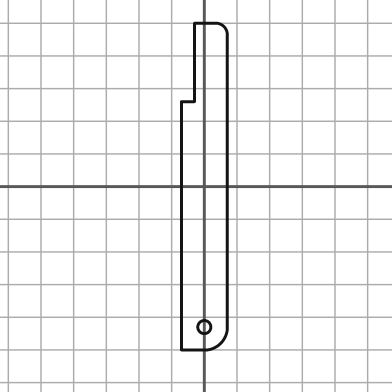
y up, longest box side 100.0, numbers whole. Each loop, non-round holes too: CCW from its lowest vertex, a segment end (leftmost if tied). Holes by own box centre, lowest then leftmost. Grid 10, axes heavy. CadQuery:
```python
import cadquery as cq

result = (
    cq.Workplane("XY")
    .moveTo(-7.0, -50.0)
    .lineTo(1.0, -50.0)
    .threePointArc((5.0, -48.0), (7.0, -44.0))
    .lineTo(7.0, 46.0)
    .threePointArc((6.0, 49.0), (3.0, 50.0))
    .lineTo(-3.0, 50.0)
    .lineTo(-3.0, 26.0)
    .lineTo(-7.0, 26.0)
    .close()
    .moveTo(0.0, -43.0)
    .circle(2.0)
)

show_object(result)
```